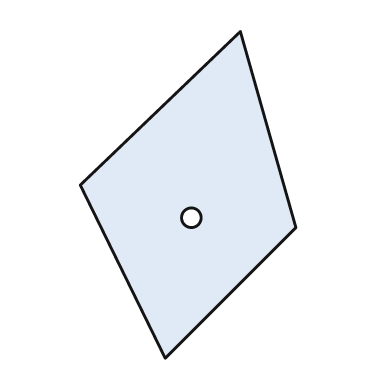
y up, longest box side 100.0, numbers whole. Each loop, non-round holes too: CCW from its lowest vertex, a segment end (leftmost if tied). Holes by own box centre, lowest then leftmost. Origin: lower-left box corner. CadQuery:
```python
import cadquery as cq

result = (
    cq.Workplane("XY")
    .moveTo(26.0, 0.0)
    .lineTo(66.0, 40.0)
    .lineTo(49.0, 100.0)
    .lineTo(0.0, 53.0)
    .close()
    .moveTo(34.0, 43.0)
    .circle(3.0)
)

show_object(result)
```